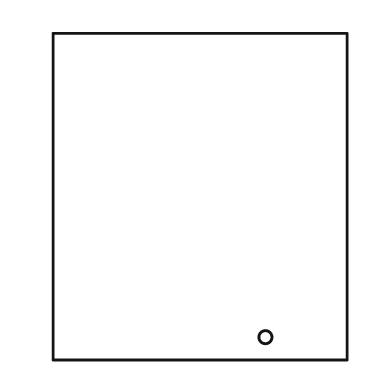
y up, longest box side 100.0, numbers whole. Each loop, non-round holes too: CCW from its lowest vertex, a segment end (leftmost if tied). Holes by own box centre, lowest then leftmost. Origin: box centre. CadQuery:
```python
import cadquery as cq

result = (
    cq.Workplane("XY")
    .moveTo(-45.0, -50.0)
    .lineTo(45.0, -50.0)
    .lineTo(45.0, 50.0)
    .lineTo(-45.0, 50.0)
    .close()
    .moveTo(20.0, -43.0)
    .circle(2.0)
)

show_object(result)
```